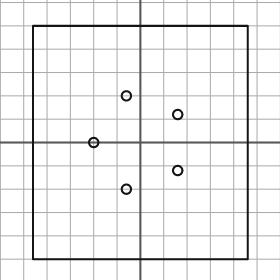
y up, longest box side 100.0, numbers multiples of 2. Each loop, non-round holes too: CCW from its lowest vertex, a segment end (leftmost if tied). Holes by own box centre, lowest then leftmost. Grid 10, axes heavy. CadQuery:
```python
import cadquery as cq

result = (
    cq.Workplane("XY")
    .moveTo(-46.0, -50.0)
    .lineTo(46.0, -50.0)
    .lineTo(46.0, 50.0)
    .lineTo(-46.0, 50.0)
    .close()
    .moveTo(-6.0, -20.0)
    .circle(2.0)
    .moveTo(16.0, -12.0)
    .circle(2.0)
    .moveTo(-20.0, 0.0)
    .circle(2.0)
    .moveTo(16.0, 12.0)
    .circle(2.0)
    .moveTo(-6.0, 20.0)
    .circle(2.0)
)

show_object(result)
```